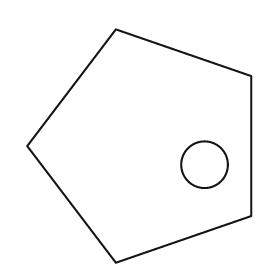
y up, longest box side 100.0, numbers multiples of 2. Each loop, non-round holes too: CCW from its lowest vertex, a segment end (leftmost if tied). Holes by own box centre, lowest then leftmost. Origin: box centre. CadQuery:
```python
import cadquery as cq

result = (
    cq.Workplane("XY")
    .moveTo(-10.0, -50.0)
    .lineTo(48.0, -30.0)
    .lineTo(48.0, 30.0)
    .lineTo(-10.0, 50.0)
    .lineTo(-48.0, 0.0)
    .close()
    .moveTo(28.0, -8.0)
    .circle(10.0)
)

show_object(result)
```